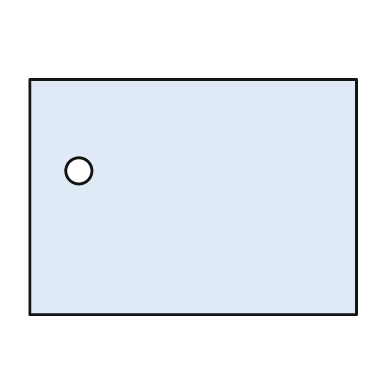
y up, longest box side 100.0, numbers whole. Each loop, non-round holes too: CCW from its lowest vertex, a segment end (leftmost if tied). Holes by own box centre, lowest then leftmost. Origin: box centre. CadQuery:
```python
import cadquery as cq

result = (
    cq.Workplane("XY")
    .moveTo(-50.0, -36.0)
    .lineTo(50.0, -36.0)
    .lineTo(50.0, 36.0)
    .lineTo(-50.0, 36.0)
    .close()
    .moveTo(-35.0, 8.0)
    .circle(4.0)
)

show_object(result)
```